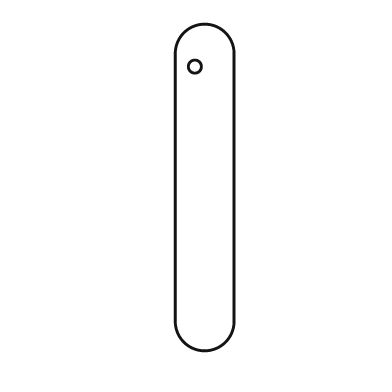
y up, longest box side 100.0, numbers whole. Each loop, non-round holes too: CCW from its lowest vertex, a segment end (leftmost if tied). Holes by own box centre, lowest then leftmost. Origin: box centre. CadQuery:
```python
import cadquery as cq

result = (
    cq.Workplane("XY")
    .moveTo(-9.0, -41.0)
    .threePointArc((0.0, -50.0), (9.0, -41.0))
    .lineTo(9.0, 41.0)
    .threePointArc((0.0, 50.0), (-9.0, 41.0))
    .close()
    .moveTo(-3.0, 37.0)
    .circle(2.0)
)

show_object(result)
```